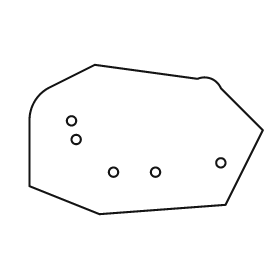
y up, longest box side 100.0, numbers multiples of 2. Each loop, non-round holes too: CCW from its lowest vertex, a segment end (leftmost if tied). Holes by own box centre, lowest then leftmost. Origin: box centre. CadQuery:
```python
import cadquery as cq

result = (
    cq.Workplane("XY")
    .moveTo(-20.0, -32.0)
    .lineTo(34.0, -28.0)
    .lineTo(50.0, 4.0)
    .lineTo(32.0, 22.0)
    .threePointArc((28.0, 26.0), (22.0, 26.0))
    .lineTo(-22.0, 32.0)
    .lineTo(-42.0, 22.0)
    .threePointArc((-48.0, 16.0), (-50.0, 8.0))
    .lineTo(-50.0, -20.0)
    .close()
    .moveTo(-14.0, -14.0)
    .circle(2.0)
    .moveTo(4.0, -14.0)
    .circle(2.0)
    .moveTo(32.0, -10.0)
    .circle(2.0)
    .moveTo(-30.0, 0.0)
    .circle(2.0)
    .moveTo(-32.0, 8.0)
    .circle(2.0)
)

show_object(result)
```